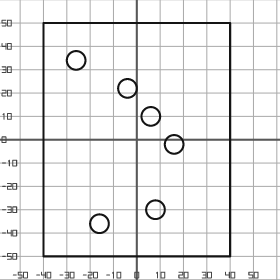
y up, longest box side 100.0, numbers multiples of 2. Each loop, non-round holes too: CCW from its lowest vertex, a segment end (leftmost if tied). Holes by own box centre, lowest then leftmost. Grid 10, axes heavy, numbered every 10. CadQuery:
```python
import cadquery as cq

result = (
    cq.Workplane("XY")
    .moveTo(-40.0, -50.0)
    .lineTo(40.0, -50.0)
    .lineTo(40.0, 50.0)
    .lineTo(-40.0, 50.0)
    .close()
    .moveTo(-16.0, -36.0)
    .circle(4.0)
    .moveTo(8.0, -30.0)
    .circle(4.0)
    .moveTo(16.0, -2.0)
    .circle(4.0)
    .moveTo(6.0, 10.0)
    .circle(4.0)
    .moveTo(-4.0, 22.0)
    .circle(4.0)
    .moveTo(-26.0, 34.0)
    .circle(4.0)
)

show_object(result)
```